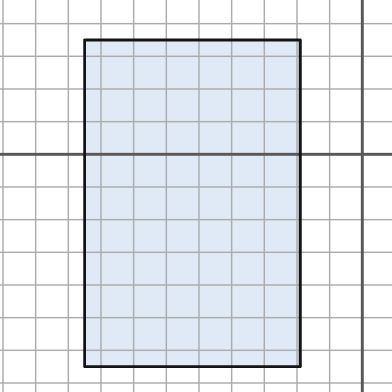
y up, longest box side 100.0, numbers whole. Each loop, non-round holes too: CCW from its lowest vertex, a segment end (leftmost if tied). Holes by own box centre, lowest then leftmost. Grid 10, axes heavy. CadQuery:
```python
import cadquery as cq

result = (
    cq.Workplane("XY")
    .moveTo(-85.0, -65.0)
    .lineTo(-19.0, -65.0)
    .lineTo(-19.0, 35.0)
    .lineTo(-85.0, 35.0)
    .close()
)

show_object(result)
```